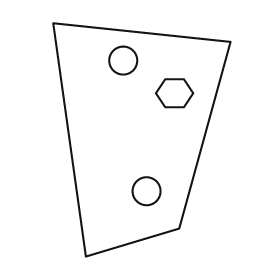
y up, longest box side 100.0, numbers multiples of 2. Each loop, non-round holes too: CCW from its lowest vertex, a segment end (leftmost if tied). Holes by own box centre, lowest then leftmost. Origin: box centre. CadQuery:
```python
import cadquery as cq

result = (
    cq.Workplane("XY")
    .moveTo(-24.0, -50.0)
    .lineTo(16.0, -38.0)
    .lineTo(38.0, 42.0)
    .lineTo(-38.0, 50.0)
    .close()
    .moveTo(2.0, -22.0)
    .circle(6.0)
    .moveTo(10.0, 14.0)
    .lineTo(18.0, 14.0)
    .lineTo(22.0, 20.0)
    .lineTo(18.0, 26.0)
    .lineTo(10.0, 26.0)
    .lineTo(6.0, 20.0)
    .close()
    .moveTo(-8.0, 34.0)
    .circle(6.0)
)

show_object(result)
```